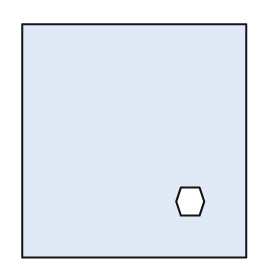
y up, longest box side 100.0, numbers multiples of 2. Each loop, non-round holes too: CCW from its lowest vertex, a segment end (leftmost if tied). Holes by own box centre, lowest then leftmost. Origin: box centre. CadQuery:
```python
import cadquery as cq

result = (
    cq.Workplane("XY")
    .moveTo(-48.0, -50.0)
    .lineTo(48.0, -50.0)
    .lineTo(48.0, 50.0)
    .lineTo(-48.0, 50.0)
    .close()
    .moveTo(20.0, -32.0)
    .lineTo(28.0, -32.0)
    .lineTo(30.0, -26.0)
    .lineTo(28.0, -20.0)
    .lineTo(20.0, -20.0)
    .lineTo(18.0, -26.0)
    .close()
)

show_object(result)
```